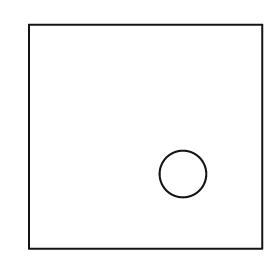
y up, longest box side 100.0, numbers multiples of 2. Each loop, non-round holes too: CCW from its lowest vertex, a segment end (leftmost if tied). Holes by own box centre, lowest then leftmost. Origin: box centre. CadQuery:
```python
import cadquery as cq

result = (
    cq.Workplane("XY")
    .moveTo(-50.0, -48.0)
    .lineTo(50.0, -48.0)
    .lineTo(50.0, 48.0)
    .lineTo(-50.0, 48.0)
    .close()
    .moveTo(16.0, -16.0)
    .circle(10.0)
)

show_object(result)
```